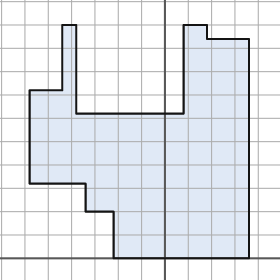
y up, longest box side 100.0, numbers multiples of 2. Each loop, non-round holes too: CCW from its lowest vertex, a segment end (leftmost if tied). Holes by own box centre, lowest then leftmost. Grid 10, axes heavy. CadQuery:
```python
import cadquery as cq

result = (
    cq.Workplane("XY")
    .moveTo(-22.0, 0.0)
    .lineTo(36.0, 0.0)
    .lineTo(36.0, 94.0)
    .lineTo(18.0, 94.0)
    .lineTo(18.0, 100.0)
    .lineTo(8.0, 100.0)
    .lineTo(8.0, 62.0)
    .lineTo(-38.0, 62.0)
    .lineTo(-38.0, 100.0)
    .lineTo(-44.0, 100.0)
    .lineTo(-44.0, 72.0)
    .lineTo(-58.0, 72.0)
    .lineTo(-58.0, 32.0)
    .lineTo(-34.0, 32.0)
    .lineTo(-34.0, 20.0)
    .lineTo(-22.0, 20.0)
    .close()
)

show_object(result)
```